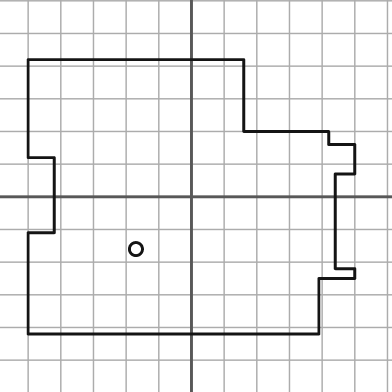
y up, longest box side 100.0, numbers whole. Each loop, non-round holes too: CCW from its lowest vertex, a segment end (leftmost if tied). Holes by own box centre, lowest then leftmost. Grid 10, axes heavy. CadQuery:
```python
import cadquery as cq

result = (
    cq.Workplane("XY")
    .moveTo(-50.0, -42.0)
    .lineTo(39.0, -42.0)
    .lineTo(39.0, -25.0)
    .lineTo(50.0, -25.0)
    .lineTo(50.0, -22.0)
    .lineTo(44.0, -22.0)
    .lineTo(44.0, 7.0)
    .lineTo(50.0, 7.0)
    .lineTo(50.0, 16.0)
    .lineTo(42.0, 16.0)
    .lineTo(42.0, 20.0)
    .lineTo(16.0, 20.0)
    .lineTo(16.0, 42.0)
    .lineTo(-50.0, 42.0)
    .lineTo(-50.0, 12.0)
    .lineTo(-42.0, 12.0)
    .lineTo(-42.0, -11.0)
    .lineTo(-50.0, -11.0)
    .close()
    .moveTo(-17.0, -16.0)
    .circle(2.0)
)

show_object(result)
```